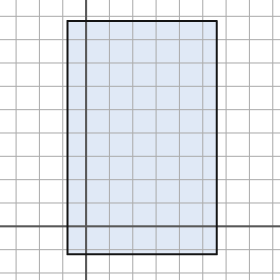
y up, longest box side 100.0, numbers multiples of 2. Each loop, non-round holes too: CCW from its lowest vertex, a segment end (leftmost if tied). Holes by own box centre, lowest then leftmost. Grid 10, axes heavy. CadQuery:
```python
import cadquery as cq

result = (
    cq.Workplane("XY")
    .moveTo(-8.0, -12.0)
    .lineTo(56.0, -12.0)
    .lineTo(56.0, 88.0)
    .lineTo(-8.0, 88.0)
    .close()
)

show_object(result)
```